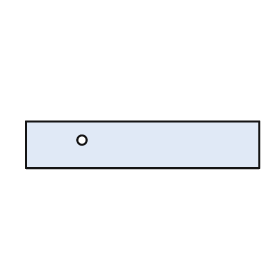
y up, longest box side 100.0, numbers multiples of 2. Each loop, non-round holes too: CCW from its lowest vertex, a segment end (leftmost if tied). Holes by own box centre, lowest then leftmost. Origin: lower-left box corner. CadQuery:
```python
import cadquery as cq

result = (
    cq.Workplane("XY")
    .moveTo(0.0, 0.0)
    .lineTo(100.0, 0.0)
    .lineTo(100.0, 20.0)
    .lineTo(0.0, 20.0)
    .close()
    .moveTo(24.0, 12.0)
    .circle(2.0)
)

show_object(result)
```